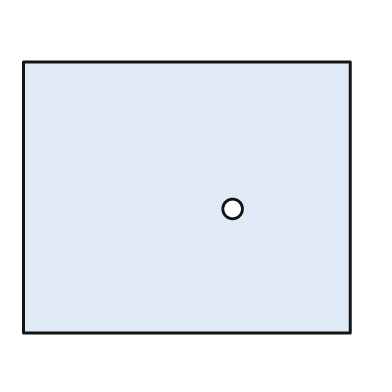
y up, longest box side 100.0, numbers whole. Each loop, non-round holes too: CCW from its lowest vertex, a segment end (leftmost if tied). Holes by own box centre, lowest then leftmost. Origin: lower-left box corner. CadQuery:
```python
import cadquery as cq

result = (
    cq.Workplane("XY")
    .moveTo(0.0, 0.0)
    .lineTo(100.0, 0.0)
    .lineTo(100.0, 83.0)
    .lineTo(0.0, 83.0)
    .close()
    .moveTo(64.0, 38.0)
    .circle(3.0)
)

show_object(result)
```